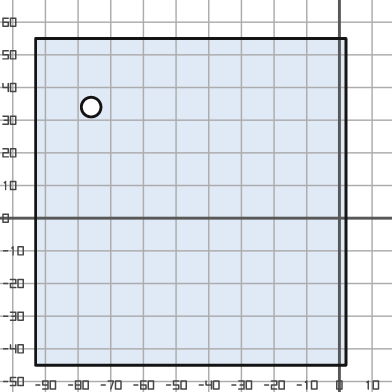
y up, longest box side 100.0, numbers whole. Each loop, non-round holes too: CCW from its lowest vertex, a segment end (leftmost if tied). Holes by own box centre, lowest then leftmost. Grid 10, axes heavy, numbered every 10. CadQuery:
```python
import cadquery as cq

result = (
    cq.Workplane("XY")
    .moveTo(-93.0, -45.0)
    .lineTo(2.0, -45.0)
    .lineTo(2.0, 55.0)
    .lineTo(-93.0, 55.0)
    .close()
    .moveTo(-76.0, 34.0)
    .circle(3.0)
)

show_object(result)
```